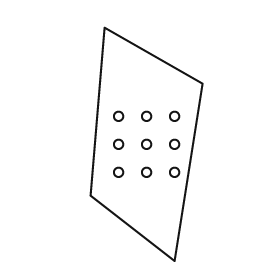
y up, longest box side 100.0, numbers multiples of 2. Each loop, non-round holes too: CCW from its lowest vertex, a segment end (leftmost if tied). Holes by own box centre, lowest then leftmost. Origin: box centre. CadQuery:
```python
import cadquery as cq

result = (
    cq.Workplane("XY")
    .moveTo(12.0, -50.0)
    .lineTo(24.0, 26.0)
    .lineTo(-18.0, 50.0)
    .lineTo(-24.0, -22.0)
    .close()
    .moveTo(-12.0, -12.0)
    .circle(2.0)
    .moveTo(0.0, -12.0)
    .circle(2.0)
    .moveTo(12.0, -12.0)
    .circle(2.0)
    .moveTo(-12.0, 0.0)
    .circle(2.0)
    .moveTo(0.0, 0.0)
    .circle(2.0)
    .moveTo(12.0, 0.0)
    .circle(2.0)
    .moveTo(-12.0, 12.0)
    .circle(2.0)
    .moveTo(0.0, 12.0)
    .circle(2.0)
    .moveTo(12.0, 12.0)
    .circle(2.0)
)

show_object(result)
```